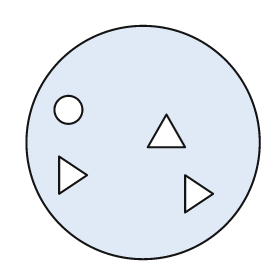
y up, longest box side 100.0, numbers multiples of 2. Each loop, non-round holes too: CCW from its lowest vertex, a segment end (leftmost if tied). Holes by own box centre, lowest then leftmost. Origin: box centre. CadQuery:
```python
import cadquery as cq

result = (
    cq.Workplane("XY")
    .moveTo(0.0, 0.0)
    .circle(50.0)
    .moveTo(18.0, -30.0)
    .lineTo(30.0, -22.0)
    .lineTo(18.0, -14.0)
    .close()
    .moveTo(-36.0, -22.0)
    .lineTo(-24.0, -14.0)
    .lineTo(-36.0, -6.0)
    .close()
    .moveTo(2.0, -2.0)
    .lineTo(18.0, -2.0)
    .lineTo(10.0, 12.0)
    .close()
    .moveTo(-32.0, 14.0)
    .circle(6.0)
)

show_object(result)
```